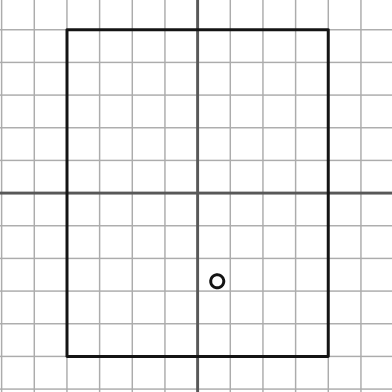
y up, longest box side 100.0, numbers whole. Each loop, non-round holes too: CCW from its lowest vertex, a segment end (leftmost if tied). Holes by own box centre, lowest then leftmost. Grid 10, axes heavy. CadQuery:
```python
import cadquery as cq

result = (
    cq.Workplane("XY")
    .moveTo(-40.0, -50.0)
    .lineTo(40.0, -50.0)
    .lineTo(40.0, 50.0)
    .lineTo(-40.0, 50.0)
    .close()
    .moveTo(6.0, -27.0)
    .circle(2.0)
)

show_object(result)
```